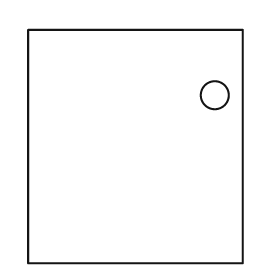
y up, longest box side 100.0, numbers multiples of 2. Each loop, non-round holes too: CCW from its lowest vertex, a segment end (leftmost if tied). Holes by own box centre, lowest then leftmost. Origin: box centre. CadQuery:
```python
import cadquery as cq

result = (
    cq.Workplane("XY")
    .moveTo(-46.0, -50.0)
    .lineTo(46.0, -50.0)
    .lineTo(46.0, 50.0)
    .lineTo(-46.0, 50.0)
    .close()
    .moveTo(34.0, 22.0)
    .circle(6.0)
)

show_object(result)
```